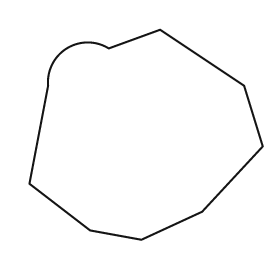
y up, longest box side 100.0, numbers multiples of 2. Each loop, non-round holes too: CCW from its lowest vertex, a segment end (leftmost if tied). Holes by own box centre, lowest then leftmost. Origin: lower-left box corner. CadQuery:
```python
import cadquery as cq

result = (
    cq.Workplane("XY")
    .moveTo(48.0, 0.0)
    .lineTo(74.0, 12.0)
    .lineTo(100.0, 40.0)
    .lineTo(92.0, 66.0)
    .lineTo(56.0, 90.0)
    .lineTo(34.0, 82.0)
    .threePointArc((16.0, 82.0), (8.0, 66.0))
    .lineTo(0.0, 24.0)
    .lineTo(26.0, 4.0)
    .close()
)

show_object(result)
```